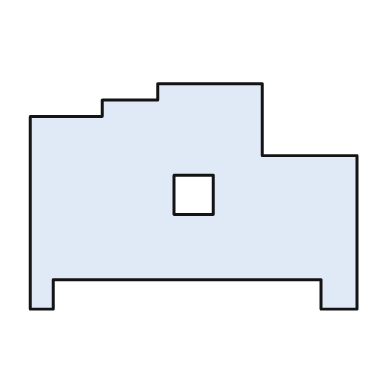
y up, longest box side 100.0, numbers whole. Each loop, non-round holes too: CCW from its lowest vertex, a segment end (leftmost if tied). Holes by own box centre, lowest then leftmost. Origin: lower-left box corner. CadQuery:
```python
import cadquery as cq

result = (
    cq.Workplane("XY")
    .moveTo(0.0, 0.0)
    .lineTo(7.0, 0.0)
    .lineTo(7.0, 9.0)
    .lineTo(89.0, 9.0)
    .lineTo(89.0, 0.0)
    .lineTo(100.0, 0.0)
    .lineTo(100.0, 47.0)
    .lineTo(71.0, 47.0)
    .lineTo(71.0, 69.0)
    .lineTo(39.0, 69.0)
    .lineTo(39.0, 64.0)
    .lineTo(22.0, 64.0)
    .lineTo(22.0, 59.0)
    .lineTo(0.0, 59.0)
    .close()
    .moveTo(44.0, 29.0)
    .lineTo(56.0, 29.0)
    .lineTo(56.0, 41.0)
    .lineTo(44.0, 41.0)
    .close()
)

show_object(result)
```